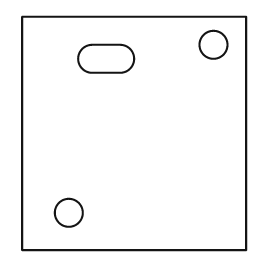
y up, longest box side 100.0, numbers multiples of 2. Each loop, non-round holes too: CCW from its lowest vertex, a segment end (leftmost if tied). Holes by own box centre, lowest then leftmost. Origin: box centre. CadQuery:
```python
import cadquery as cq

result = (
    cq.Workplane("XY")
    .moveTo(-48.0, -50.0)
    .lineTo(48.0, -50.0)
    .lineTo(48.0, 50.0)
    .lineTo(-48.0, 50.0)
    .close()
    .moveTo(-28.0, -34.0)
    .circle(6.0)
    .moveTo(-18.0, 26.0)
    .lineTo(-6.0, 26.0)
    .threePointArc((0.0, 32.0), (-6.0, 38.0))
    .lineTo(-18.0, 38.0)
    .threePointArc((-24.0, 32.0), (-18.0, 26.0))
    .close()
    .moveTo(34.0, 38.0)
    .circle(6.0)
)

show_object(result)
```